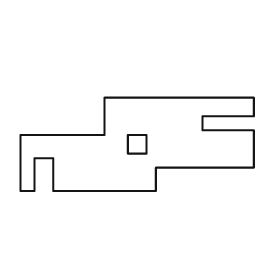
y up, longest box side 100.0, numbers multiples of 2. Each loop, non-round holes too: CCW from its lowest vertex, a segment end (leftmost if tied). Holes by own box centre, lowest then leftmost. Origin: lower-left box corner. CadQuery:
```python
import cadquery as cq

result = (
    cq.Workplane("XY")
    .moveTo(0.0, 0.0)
    .lineTo(6.0, 0.0)
    .lineTo(6.0, 14.0)
    .lineTo(14.0, 14.0)
    .lineTo(14.0, 0.0)
    .lineTo(58.0, 0.0)
    .lineTo(58.0, 10.0)
    .lineTo(100.0, 10.0)
    .lineTo(100.0, 26.0)
    .lineTo(78.0, 26.0)
    .lineTo(78.0, 32.0)
    .lineTo(100.0, 32.0)
    .lineTo(100.0, 40.0)
    .lineTo(36.0, 40.0)
    .lineTo(36.0, 24.0)
    .lineTo(0.0, 24.0)
    .close()
    .moveTo(46.0, 16.0)
    .lineTo(54.0, 16.0)
    .lineTo(54.0, 24.0)
    .lineTo(46.0, 24.0)
    .close()
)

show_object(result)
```